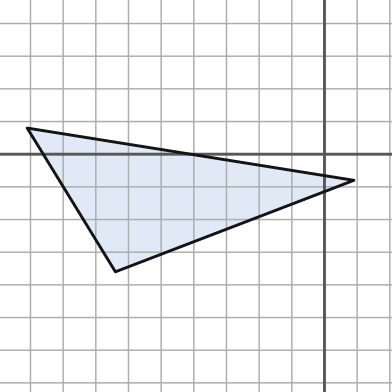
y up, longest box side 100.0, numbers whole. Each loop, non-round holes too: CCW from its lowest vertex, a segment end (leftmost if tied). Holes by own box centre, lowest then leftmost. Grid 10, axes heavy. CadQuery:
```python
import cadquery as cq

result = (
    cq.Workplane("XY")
    .moveTo(-64.0, -36.0)
    .lineTo(9.0, -8.0)
    .lineTo(-91.0, 8.0)
    .close()
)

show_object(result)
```